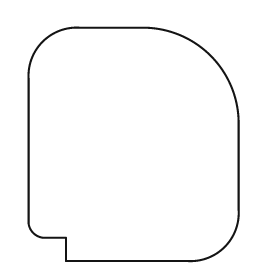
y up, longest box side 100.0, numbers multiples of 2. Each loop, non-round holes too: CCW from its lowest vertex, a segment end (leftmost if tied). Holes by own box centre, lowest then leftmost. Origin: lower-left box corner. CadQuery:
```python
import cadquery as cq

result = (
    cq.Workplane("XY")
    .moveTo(16.0, 0.0)
    .lineTo(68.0, 0.0)
    .threePointArc((84.0, 6.0), (90.0, 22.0))
    .lineTo(90.0, 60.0)
    .threePointArc((78.0, 88.0), (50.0, 100.0))
    .lineTo(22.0, 100.0)
    .threePointArc((6.0, 94.0), (0.0, 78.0))
    .lineTo(0.0, 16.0)
    .threePointArc((2.0, 12.0), (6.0, 10.0))
    .lineTo(16.0, 10.0)
    .close()
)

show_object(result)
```